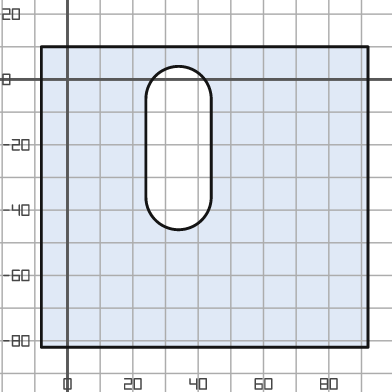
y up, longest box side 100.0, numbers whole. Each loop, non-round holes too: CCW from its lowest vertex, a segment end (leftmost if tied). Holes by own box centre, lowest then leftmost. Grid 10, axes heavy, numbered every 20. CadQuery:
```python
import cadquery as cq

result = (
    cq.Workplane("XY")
    .moveTo(-8.0, -82.0)
    .lineTo(92.0, -82.0)
    .lineTo(92.0, 10.0)
    .lineTo(-8.0, 10.0)
    .close()
    .moveTo(24.0, -36.0)
    .threePointArc((34.0, -46.0), (44.0, -36.0))
    .lineTo(44.0, -6.0)
    .threePointArc((34.0, 4.0), (24.0, -6.0))
    .close()
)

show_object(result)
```